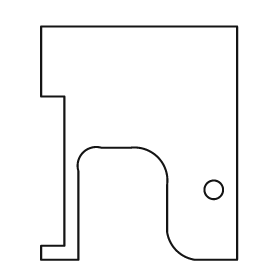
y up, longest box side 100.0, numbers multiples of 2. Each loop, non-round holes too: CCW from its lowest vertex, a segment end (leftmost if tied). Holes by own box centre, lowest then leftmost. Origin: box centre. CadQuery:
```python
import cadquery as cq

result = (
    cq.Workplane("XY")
    .moveTo(-42.0, -50.0)
    .lineTo(-26.0, -50.0)
    .lineTo(-26.0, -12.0)
    .threePointArc((-24.0, -4.0), (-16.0, -2.0))
    .lineTo(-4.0, -2.0)
    .threePointArc((8.0, -6.0), (12.0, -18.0))
    .lineTo(12.0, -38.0)
    .threePointArc((16.0, -46.0), (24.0, -50.0))
    .lineTo(42.0, -50.0)
    .lineTo(42.0, 50.0)
    .lineTo(-42.0, 50.0)
    .lineTo(-42.0, 20.0)
    .lineTo(-32.0, 20.0)
    .lineTo(-32.0, -44.0)
    .lineTo(-42.0, -44.0)
    .close()
    .moveTo(32.0, -20.0)
    .circle(4.0)
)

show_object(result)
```